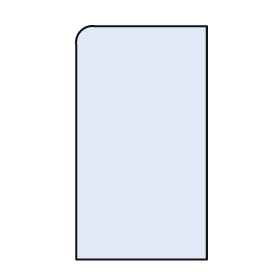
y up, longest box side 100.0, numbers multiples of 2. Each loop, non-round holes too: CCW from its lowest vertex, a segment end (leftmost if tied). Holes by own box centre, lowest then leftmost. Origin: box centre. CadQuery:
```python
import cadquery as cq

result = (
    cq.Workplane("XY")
    .moveTo(-28.0, -50.0)
    .lineTo(28.0, -50.0)
    .lineTo(28.0, 50.0)
    .lineTo(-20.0, 50.0)
    .threePointArc((-26.0, 48.0), (-28.0, 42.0))
    .close()
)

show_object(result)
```